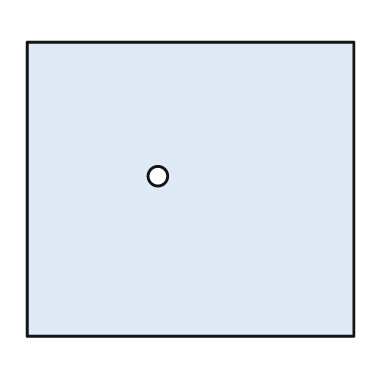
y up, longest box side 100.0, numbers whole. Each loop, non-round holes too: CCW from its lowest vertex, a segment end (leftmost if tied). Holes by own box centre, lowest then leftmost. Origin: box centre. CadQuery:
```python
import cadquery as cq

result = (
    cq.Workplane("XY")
    .moveTo(-50.0, -45.0)
    .lineTo(50.0, -45.0)
    .lineTo(50.0, 45.0)
    .lineTo(-50.0, 45.0)
    .close()
    .moveTo(-10.0, 4.0)
    .circle(3.0)
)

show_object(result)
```